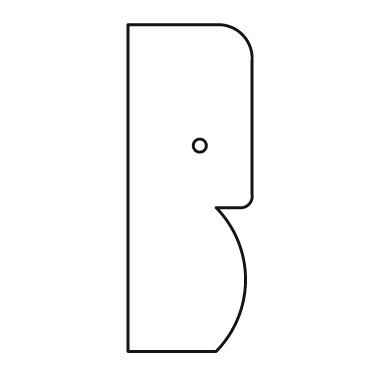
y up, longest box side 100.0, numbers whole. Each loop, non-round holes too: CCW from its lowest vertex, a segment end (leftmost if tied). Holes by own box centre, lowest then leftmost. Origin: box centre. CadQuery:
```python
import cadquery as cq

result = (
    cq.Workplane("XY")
    .moveTo(-19.0, -50.0)
    .lineTo(8.0, -50.0)
    .threePointArc((17.0, -28.0), (8.0, -6.0))
    .lineTo(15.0, -6.0)
    .threePointArc((18.0, -5.0), (19.0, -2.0))
    .lineTo(19.0, 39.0)
    .threePointArc((16.0, 47.0), (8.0, 50.0))
    .lineTo(-19.0, 50.0)
    .close()
    .moveTo(3.0, 13.0)
    .circle(2.0)
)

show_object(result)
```